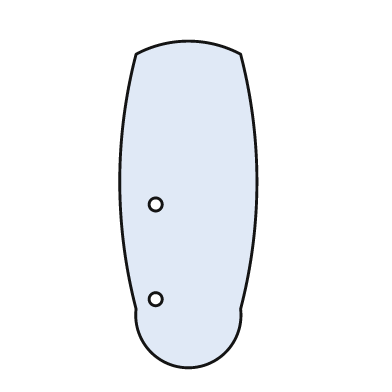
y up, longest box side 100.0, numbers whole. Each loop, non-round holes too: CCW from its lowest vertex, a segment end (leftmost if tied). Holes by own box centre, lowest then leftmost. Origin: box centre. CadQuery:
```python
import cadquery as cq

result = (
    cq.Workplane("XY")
    .moveTo(-16.0, -32.0)
    .threePointArc((0.0, -50.0), (16.0, -32.0))
    .threePointArc((21.0, 7.0), (16.0, 46.0))
    .threePointArc((0.0, 50.0), (-16.0, 46.0))
    .threePointArc((-21.0, 7.0), (-16.0, -32.0))
    .close()
    .moveTo(-10.0, -29.0)
    .circle(2.0)
    .moveTo(-10.0, 0.0)
    .circle(2.0)
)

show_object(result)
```